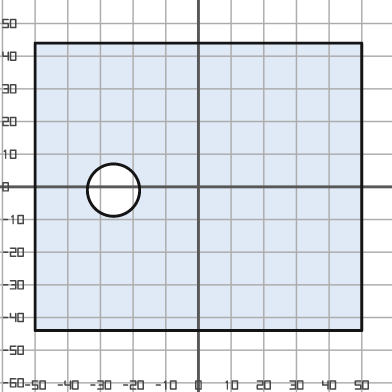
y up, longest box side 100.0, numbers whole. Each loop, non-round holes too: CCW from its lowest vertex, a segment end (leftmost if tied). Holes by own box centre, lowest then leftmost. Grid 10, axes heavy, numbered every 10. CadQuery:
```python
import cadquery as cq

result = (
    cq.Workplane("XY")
    .moveTo(-50.0, -44.0)
    .lineTo(50.0, -44.0)
    .lineTo(50.0, 44.0)
    .lineTo(-50.0, 44.0)
    .close()
    .moveTo(-26.0, -1.0)
    .circle(8.0)
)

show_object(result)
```